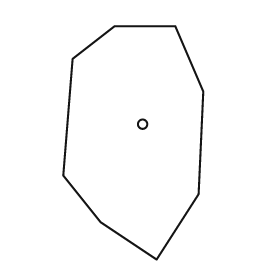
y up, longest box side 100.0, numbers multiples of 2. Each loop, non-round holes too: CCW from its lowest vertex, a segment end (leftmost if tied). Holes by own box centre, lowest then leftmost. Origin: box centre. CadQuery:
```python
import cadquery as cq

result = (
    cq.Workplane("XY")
    .moveTo(10.0, -50.0)
    .lineTo(28.0, -22.0)
    .lineTo(30.0, 22.0)
    .lineTo(18.0, 50.0)
    .lineTo(-8.0, 50.0)
    .lineTo(-26.0, 36.0)
    .lineTo(-30.0, -14.0)
    .lineTo(-14.0, -34.0)
    .close()
    .moveTo(4.0, 8.0)
    .circle(2.0)
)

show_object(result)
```